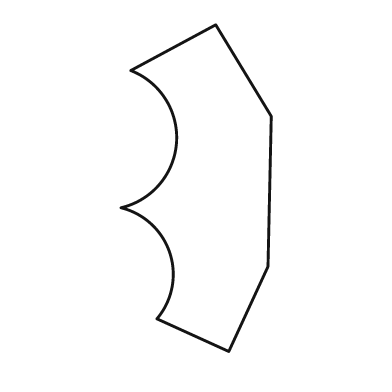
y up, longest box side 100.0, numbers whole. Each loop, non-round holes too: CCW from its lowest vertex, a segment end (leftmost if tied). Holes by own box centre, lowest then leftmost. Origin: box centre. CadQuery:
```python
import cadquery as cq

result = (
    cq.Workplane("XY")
    .moveTo(10.0, -50.0)
    .lineTo(22.0, -24.0)
    .lineTo(23.0, 22.0)
    .lineTo(6.0, 50.0)
    .lineTo(-20.0, 36.0)
    .threePointArc((-6.0, 14.0), (-23.0, -6.0))
    .threePointArc((-8.0, -20.0), (-12.0, -40.0))
    .close()
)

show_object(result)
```